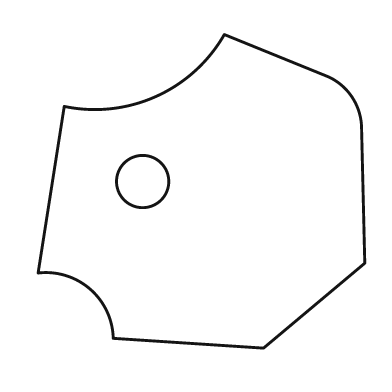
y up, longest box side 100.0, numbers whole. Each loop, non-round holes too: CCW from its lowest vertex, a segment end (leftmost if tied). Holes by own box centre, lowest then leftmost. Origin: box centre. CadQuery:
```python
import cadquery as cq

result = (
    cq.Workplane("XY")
    .moveTo(19.0, -48.0)
    .lineTo(50.0, -22.0)
    .lineTo(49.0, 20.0)
    .threePointArc((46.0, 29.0), (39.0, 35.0))
    .lineTo(7.0, 48.0)
    .threePointArc((-14.0, 29.0), (-42.0, 26.0))
    .lineTo(-50.0, -25.0)
    .threePointArc((-34.0, -30.0), (-27.0, -45.0))
    .close()
    .moveTo(-18.0, 3.0)
    .circle(8.0)
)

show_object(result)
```